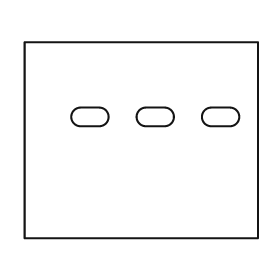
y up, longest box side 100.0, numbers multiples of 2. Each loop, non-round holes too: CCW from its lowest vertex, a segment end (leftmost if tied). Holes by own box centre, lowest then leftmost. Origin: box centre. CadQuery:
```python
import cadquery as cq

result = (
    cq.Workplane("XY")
    .moveTo(-50.0, -42.0)
    .lineTo(50.0, -42.0)
    .lineTo(50.0, 42.0)
    .lineTo(-50.0, 42.0)
    .close()
    .moveTo(-26.0, 6.0)
    .lineTo(-18.0, 6.0)
    .threePointArc((-14.0, 10.0), (-18.0, 14.0))
    .lineTo(-26.0, 14.0)
    .threePointArc((-30.0, 10.0), (-26.0, 6.0))
    .close()
    .moveTo(2.0, 6.0)
    .lineTo(10.0, 6.0)
    .threePointArc((14.0, 10.0), (10.0, 14.0))
    .lineTo(2.0, 14.0)
    .threePointArc((-2.0, 10.0), (2.0, 6.0))
    .close()
    .moveTo(30.0, 6.0)
    .lineTo(38.0, 6.0)
    .threePointArc((42.0, 10.0), (38.0, 14.0))
    .lineTo(30.0, 14.0)
    .threePointArc((26.0, 10.0), (30.0, 6.0))
    .close()
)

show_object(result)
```